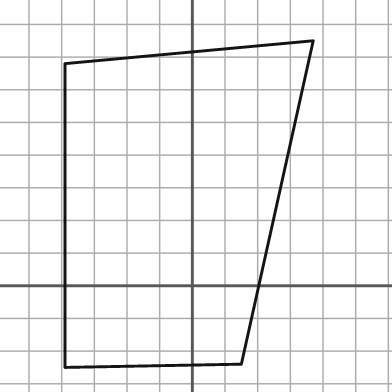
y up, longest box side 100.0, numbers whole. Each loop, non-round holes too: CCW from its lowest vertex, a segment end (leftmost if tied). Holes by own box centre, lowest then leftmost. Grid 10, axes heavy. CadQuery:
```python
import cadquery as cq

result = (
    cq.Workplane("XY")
    .moveTo(-39.0, -25.0)
    .lineTo(15.0, -24.0)
    .lineTo(37.0, 75.0)
    .lineTo(-39.0, 68.0)
    .close()
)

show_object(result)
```